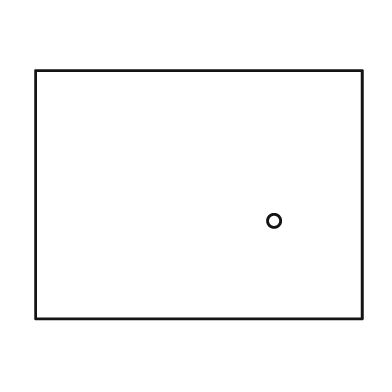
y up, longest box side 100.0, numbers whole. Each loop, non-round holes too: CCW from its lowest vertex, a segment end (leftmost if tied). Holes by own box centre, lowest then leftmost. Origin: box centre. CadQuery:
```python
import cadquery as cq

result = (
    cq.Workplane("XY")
    .moveTo(-50.0, -38.0)
    .lineTo(50.0, -38.0)
    .lineTo(50.0, 38.0)
    .lineTo(-50.0, 38.0)
    .close()
    .moveTo(23.0, -8.0)
    .circle(2.0)
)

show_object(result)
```